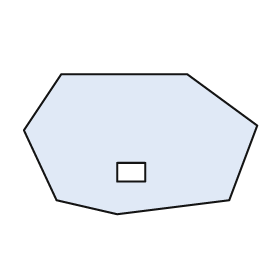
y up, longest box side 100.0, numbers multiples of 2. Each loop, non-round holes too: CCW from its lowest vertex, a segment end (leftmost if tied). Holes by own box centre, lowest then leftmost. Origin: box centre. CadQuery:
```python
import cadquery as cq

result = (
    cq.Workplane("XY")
    .moveTo(-10.0, -30.0)
    .lineTo(38.0, -24.0)
    .lineTo(50.0, 8.0)
    .lineTo(20.0, 30.0)
    .lineTo(-34.0, 30.0)
    .lineTo(-50.0, 6.0)
    .lineTo(-36.0, -24.0)
    .close()
    .moveTo(-10.0, -16.0)
    .lineTo(2.0, -16.0)
    .lineTo(2.0, -8.0)
    .lineTo(-10.0, -8.0)
    .close()
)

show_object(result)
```